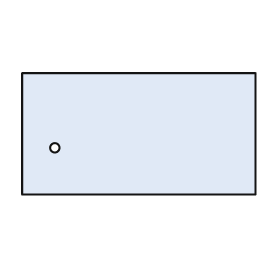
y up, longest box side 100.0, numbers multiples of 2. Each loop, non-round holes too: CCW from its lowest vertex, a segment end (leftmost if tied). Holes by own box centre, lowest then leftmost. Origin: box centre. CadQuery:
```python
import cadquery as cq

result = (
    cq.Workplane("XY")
    .moveTo(-50.0, -26.0)
    .lineTo(50.0, -26.0)
    .lineTo(50.0, 26.0)
    .lineTo(-50.0, 26.0)
    .close()
    .moveTo(-36.0, -6.0)
    .circle(2.0)
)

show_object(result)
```